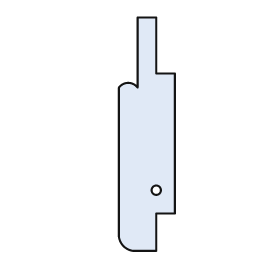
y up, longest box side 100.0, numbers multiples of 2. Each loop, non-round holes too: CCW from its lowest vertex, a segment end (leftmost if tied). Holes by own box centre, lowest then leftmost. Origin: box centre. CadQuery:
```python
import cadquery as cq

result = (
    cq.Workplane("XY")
    .moveTo(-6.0, -50.0)
    .lineTo(4.0, -50.0)
    .lineTo(4.0, -34.0)
    .lineTo(12.0, -34.0)
    .lineTo(12.0, 26.0)
    .lineTo(4.0, 26.0)
    .lineTo(4.0, 50.0)
    .lineTo(-4.0, 50.0)
    .lineTo(-4.0, 20.0)
    .threePointArc((-8.0, 22.0), (-12.0, 20.0))
    .lineTo(-12.0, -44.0)
    .threePointArc((-10.0, -48.0), (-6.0, -50.0))
    .close()
    .moveTo(4.0, -24.0)
    .circle(2.0)
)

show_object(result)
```